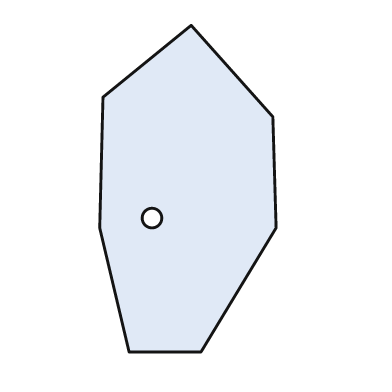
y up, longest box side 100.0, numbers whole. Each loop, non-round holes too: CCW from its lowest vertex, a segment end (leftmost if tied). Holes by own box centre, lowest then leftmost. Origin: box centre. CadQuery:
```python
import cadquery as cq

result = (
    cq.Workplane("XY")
    .moveTo(-18.0, -50.0)
    .lineTo(4.0, -50.0)
    .lineTo(27.0, -12.0)
    .lineTo(26.0, 22.0)
    .lineTo(1.0, 50.0)
    .lineTo(-26.0, 28.0)
    .lineTo(-27.0, -12.0)
    .close()
    .moveTo(-11.0, -9.0)
    .circle(3.0)
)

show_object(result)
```